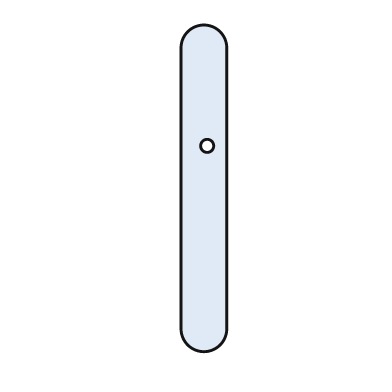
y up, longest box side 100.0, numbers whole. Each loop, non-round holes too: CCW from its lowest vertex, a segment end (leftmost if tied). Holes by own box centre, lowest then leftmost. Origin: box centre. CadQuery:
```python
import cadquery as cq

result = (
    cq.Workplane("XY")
    .moveTo(-7.0, -43.0)
    .threePointArc((0.0, -50.0), (7.0, -43.0))
    .lineTo(7.0, 43.0)
    .threePointArc((0.0, 50.0), (-7.0, 43.0))
    .close()
    .moveTo(1.0, 13.0)
    .circle(2.0)
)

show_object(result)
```